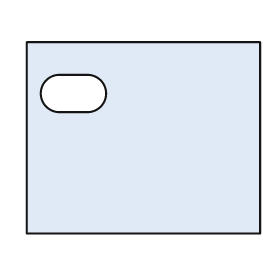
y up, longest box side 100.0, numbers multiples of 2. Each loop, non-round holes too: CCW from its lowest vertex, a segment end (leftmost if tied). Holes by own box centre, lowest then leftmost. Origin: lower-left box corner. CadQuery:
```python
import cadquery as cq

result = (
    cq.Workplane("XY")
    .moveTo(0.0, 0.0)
    .lineTo(100.0, 0.0)
    .lineTo(100.0, 82.0)
    .lineTo(0.0, 82.0)
    .close()
    .moveTo(14.0, 52.0)
    .lineTo(26.0, 52.0)
    .threePointArc((34.0, 60.0), (26.0, 68.0))
    .lineTo(14.0, 68.0)
    .threePointArc((6.0, 60.0), (14.0, 52.0))
    .close()
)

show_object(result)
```